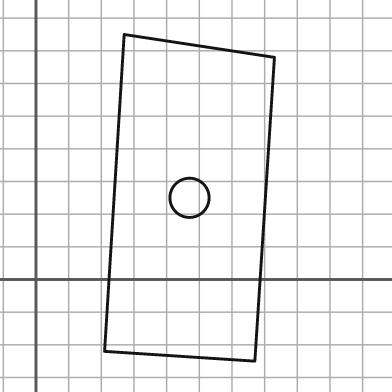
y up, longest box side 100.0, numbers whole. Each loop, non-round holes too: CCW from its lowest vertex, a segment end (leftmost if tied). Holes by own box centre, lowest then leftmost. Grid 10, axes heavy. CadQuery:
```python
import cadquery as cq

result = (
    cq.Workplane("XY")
    .moveTo(67.0, -25.0)
    .lineTo(73.0, 68.0)
    .lineTo(27.0, 75.0)
    .lineTo(21.0, -22.0)
    .close()
    .moveTo(47.0, 25.0)
    .circle(6.0)
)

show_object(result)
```